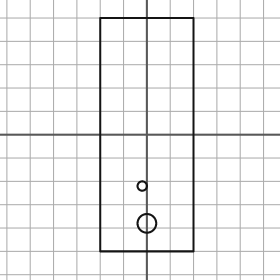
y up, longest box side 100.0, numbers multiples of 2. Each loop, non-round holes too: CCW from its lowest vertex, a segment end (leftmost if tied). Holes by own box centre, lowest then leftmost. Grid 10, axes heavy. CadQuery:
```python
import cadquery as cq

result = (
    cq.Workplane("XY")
    .moveTo(-20.0, -50.0)
    .lineTo(20.0, -50.0)
    .lineTo(20.0, 50.0)
    .lineTo(-20.0, 50.0)
    .close()
    .moveTo(0.0, -38.0)
    .circle(4.0)
    .moveTo(-2.0, -22.0)
    .circle(2.0)
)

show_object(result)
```